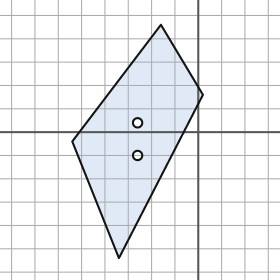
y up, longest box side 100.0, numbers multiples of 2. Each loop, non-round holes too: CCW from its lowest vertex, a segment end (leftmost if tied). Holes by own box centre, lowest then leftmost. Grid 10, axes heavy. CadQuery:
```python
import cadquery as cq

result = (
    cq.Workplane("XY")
    .moveTo(-34.0, -54.0)
    .lineTo(2.0, 16.0)
    .lineTo(-16.0, 46.0)
    .lineTo(-54.0, -4.0)
    .close()
    .moveTo(-26.0, -10.0)
    .circle(2.0)
    .moveTo(-26.0, 4.0)
    .circle(2.0)
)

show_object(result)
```